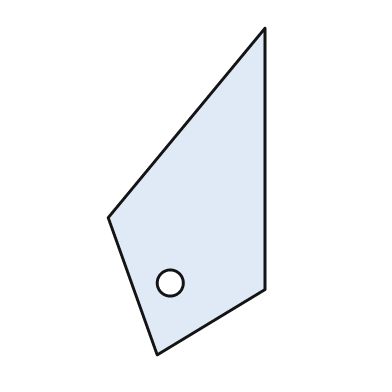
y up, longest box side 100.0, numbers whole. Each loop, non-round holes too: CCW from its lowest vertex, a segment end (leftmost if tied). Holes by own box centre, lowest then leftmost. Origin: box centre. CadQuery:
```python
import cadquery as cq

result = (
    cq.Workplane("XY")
    .moveTo(-9.0, -50.0)
    .lineTo(24.0, -30.0)
    .lineTo(24.0, 50.0)
    .lineTo(-24.0, -8.0)
    .close()
    .moveTo(-5.0, -28.0)
    .circle(4.0)
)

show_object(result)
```